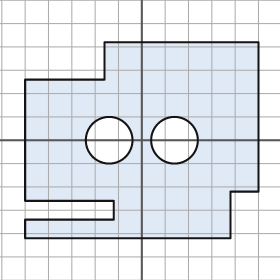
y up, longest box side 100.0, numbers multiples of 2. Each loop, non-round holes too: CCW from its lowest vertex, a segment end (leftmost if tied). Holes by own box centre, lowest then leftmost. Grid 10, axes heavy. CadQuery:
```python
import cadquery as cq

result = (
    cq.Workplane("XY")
    .moveTo(-50.0, -42.0)
    .lineTo(38.0, -42.0)
    .lineTo(38.0, -22.0)
    .lineTo(50.0, -22.0)
    .lineTo(50.0, 42.0)
    .lineTo(-16.0, 42.0)
    .lineTo(-16.0, 26.0)
    .lineTo(-50.0, 26.0)
    .lineTo(-50.0, -26.0)
    .lineTo(-12.0, -26.0)
    .lineTo(-12.0, -34.0)
    .lineTo(-50.0, -34.0)
    .close()
    .moveTo(-14.0, 0.0)
    .circle(10.0)
    .moveTo(14.0, 0.0)
    .circle(10.0)
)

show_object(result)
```